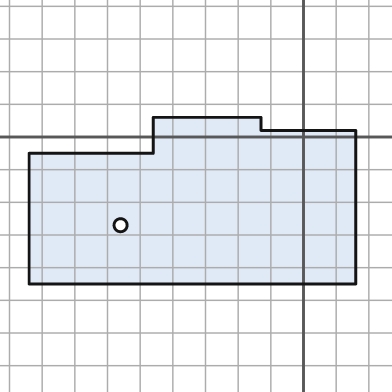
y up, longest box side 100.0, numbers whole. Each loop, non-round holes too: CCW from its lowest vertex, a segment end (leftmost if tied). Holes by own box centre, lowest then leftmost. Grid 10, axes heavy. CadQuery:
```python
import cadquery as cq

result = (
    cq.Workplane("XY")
    .moveTo(-84.0, -45.0)
    .lineTo(16.0, -45.0)
    .lineTo(16.0, 2.0)
    .lineTo(-13.0, 2.0)
    .lineTo(-13.0, 6.0)
    .lineTo(-46.0, 6.0)
    .lineTo(-46.0, -5.0)
    .lineTo(-84.0, -5.0)
    .close()
    .moveTo(-56.0, -27.0)
    .circle(2.0)
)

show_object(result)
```